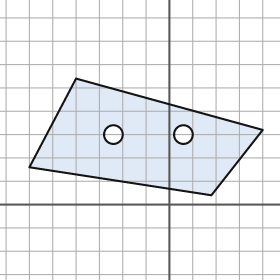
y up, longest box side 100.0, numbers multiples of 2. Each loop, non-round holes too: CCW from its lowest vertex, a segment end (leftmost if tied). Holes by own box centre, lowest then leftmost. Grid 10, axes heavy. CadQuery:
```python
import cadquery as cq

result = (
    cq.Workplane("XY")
    .moveTo(18.0, 4.0)
    .lineTo(40.0, 32.0)
    .lineTo(-40.0, 54.0)
    .lineTo(-60.0, 16.0)
    .close()
    .moveTo(-24.0, 30.0)
    .circle(4.0)
    .moveTo(6.0, 30.0)
    .circle(4.0)
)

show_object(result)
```